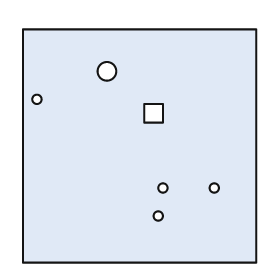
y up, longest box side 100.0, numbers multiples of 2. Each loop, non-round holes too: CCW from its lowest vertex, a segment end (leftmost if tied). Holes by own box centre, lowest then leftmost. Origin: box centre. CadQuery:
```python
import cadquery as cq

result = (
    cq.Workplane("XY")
    .moveTo(-50.0, -50.0)
    .lineTo(50.0, -50.0)
    .lineTo(50.0, 50.0)
    .lineTo(-50.0, 50.0)
    .close()
    .moveTo(8.0, -30.0)
    .circle(2.0)
    .moveTo(10.0, -18.0)
    .circle(2.0)
    .moveTo(32.0, -18.0)
    .circle(2.0)
    .moveTo(2.0, 10.0)
    .lineTo(10.0, 10.0)
    .lineTo(10.0, 18.0)
    .lineTo(2.0, 18.0)
    .close()
    .moveTo(-44.0, 20.0)
    .circle(2.0)
    .moveTo(-14.0, 32.0)
    .circle(4.0)
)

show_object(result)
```